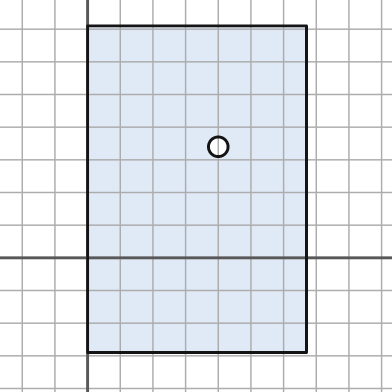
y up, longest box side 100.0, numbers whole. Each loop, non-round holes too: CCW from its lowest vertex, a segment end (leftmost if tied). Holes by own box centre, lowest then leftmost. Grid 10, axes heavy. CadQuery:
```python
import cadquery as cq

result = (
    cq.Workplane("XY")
    .moveTo(0.0, -29.0)
    .lineTo(67.0, -29.0)
    .lineTo(67.0, 71.0)
    .lineTo(0.0, 71.0)
    .close()
    .moveTo(40.0, 34.0)
    .circle(3.0)
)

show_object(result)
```